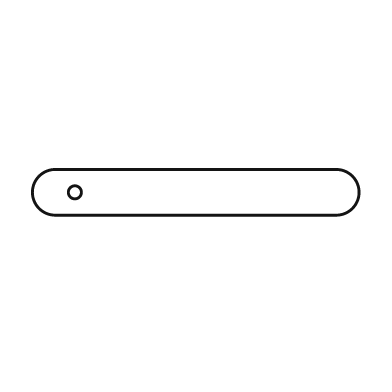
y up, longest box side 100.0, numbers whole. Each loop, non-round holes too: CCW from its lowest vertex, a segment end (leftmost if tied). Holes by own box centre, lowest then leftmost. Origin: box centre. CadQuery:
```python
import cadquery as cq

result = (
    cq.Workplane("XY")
    .moveTo(-43.0, -7.0)
    .lineTo(43.0, -7.0)
    .threePointArc((50.0, 0.0), (43.0, 7.0))
    .lineTo(-43.0, 7.0)
    .threePointArc((-50.0, 0.0), (-43.0, -7.0))
    .close()
    .moveTo(-37.0, 0.0)
    .circle(2.0)
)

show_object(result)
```